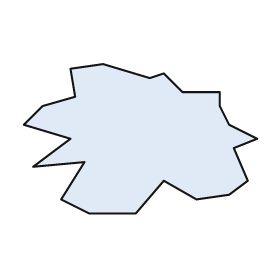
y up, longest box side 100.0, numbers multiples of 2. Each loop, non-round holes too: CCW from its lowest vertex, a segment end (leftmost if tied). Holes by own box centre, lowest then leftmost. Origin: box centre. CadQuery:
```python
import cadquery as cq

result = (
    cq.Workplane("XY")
    .moveTo(-22.0, -32.0)
    .lineTo(-2.0, -32.0)
    .lineTo(10.0, -18.0)
    .lineTo(24.0, -26.0)
    .lineTo(38.0, -24.0)
    .lineTo(46.0, -18.0)
    .lineTo(40.0, -4.0)
    .lineTo(50.0, 0.0)
    .lineTo(38.0, 6.0)
    .lineTo(34.0, 14.0)
    .lineTo(34.0, 20.0)
    .lineTo(18.0, 20.0)
    .lineTo(10.0, 28.0)
    .lineTo(4.0, 26.0)
    .lineTo(-16.0, 32.0)
    .lineTo(-30.0, 30.0)
    .lineTo(-28.0, 18.0)
    .lineTo(-42.0, 14.0)
    .lineTo(-50.0, 6.0)
    .lineTo(-30.0, 0.0)
    .lineTo(-46.0, -12.0)
    .lineTo(-24.0, -10.0)
    .lineTo(-34.0, -26.0)
    .close()
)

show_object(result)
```